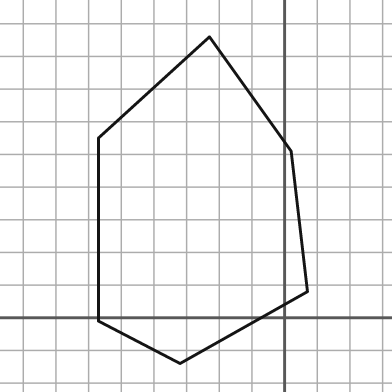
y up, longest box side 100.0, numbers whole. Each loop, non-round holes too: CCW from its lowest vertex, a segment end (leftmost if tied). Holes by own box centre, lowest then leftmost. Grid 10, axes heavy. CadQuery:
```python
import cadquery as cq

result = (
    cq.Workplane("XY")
    .moveTo(-32.0, -14.0)
    .lineTo(7.0, 8.0)
    .lineTo(2.0, 51.0)
    .lineTo(-23.0, 86.0)
    .lineTo(-57.0, 55.0)
    .lineTo(-57.0, -1.0)
    .close()
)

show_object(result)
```